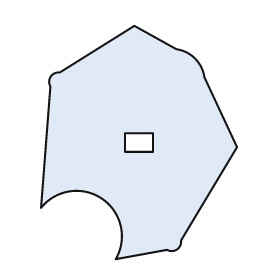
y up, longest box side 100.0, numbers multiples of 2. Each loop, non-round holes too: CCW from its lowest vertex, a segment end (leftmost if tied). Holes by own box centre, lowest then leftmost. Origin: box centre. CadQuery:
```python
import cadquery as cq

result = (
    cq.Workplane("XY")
    .moveTo(-10.0, -50.0)
    .lineTo(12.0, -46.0)
    .threePointArc((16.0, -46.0), (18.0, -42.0))
    .lineTo(42.0, -2.0)
    .lineTo(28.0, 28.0)
    .threePointArc((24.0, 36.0), (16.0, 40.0))
    .lineTo(-2.0, 50.0)
    .lineTo(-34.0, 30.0)
    .threePointArc((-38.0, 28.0), (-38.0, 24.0))
    .lineTo(-42.0, -28.0)
    .threePointArc((-16.0, -24.0), (-10.0, -50.0))
    .close()
    .moveTo(-6.0, -4.0)
    .lineTo(6.0, -4.0)
    .lineTo(6.0, 4.0)
    .lineTo(-6.0, 4.0)
    .close()
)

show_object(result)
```